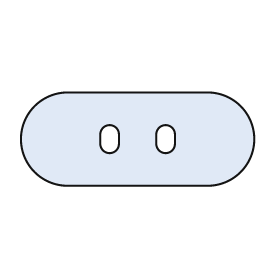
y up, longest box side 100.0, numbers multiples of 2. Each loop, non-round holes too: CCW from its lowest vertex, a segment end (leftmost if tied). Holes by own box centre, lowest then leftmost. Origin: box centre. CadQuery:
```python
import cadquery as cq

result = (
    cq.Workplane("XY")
    .moveTo(-30.0, -20.0)
    .lineTo(30.0, -20.0)
    .threePointArc((50.0, 0.0), (30.0, 20.0))
    .lineTo(-30.0, 20.0)
    .threePointArc((-50.0, 0.0), (-30.0, -20.0))
    .close()
    .moveTo(-16.0, -2.0)
    .threePointArc((-12.0, -6.0), (-8.0, -2.0))
    .lineTo(-8.0, 2.0)
    .threePointArc((-12.0, 6.0), (-16.0, 2.0))
    .close()
    .moveTo(8.0, -2.0)
    .threePointArc((12.0, -6.0), (16.0, -2.0))
    .lineTo(16.0, 2.0)
    .threePointArc((12.0, 6.0), (8.0, 2.0))
    .close()
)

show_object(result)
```